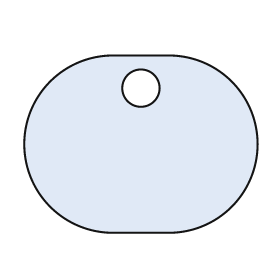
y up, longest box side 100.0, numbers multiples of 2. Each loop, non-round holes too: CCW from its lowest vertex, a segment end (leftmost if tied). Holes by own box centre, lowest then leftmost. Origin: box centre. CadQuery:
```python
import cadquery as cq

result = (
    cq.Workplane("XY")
    .moveTo(-12.0, -38.0)
    .lineTo(12.0, -38.0)
    .threePointArc((50.0, 0.0), (12.0, 38.0))
    .lineTo(-12.0, 38.0)
    .threePointArc((-50.0, 0.0), (-12.0, -38.0))
    .close()
    .moveTo(0.0, 24.0)
    .circle(8.0)
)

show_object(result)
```